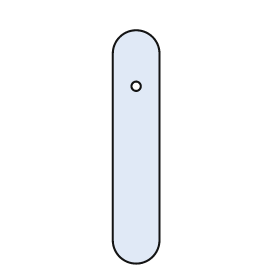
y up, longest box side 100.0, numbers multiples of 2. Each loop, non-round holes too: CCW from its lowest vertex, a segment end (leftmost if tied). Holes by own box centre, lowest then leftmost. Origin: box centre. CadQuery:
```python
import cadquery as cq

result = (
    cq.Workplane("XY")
    .moveTo(-10.0, -40.0)
    .threePointArc((0.0, -50.0), (10.0, -40.0))
    .lineTo(10.0, 40.0)
    .threePointArc((0.0, 50.0), (-10.0, 40.0))
    .close()
    .moveTo(0.0, 26.0)
    .circle(2.0)
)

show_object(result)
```